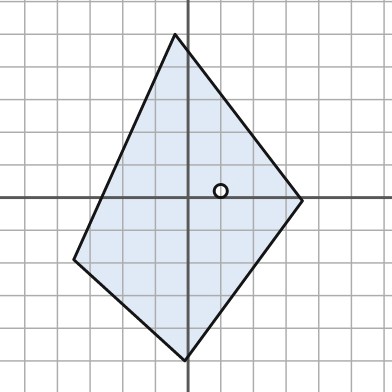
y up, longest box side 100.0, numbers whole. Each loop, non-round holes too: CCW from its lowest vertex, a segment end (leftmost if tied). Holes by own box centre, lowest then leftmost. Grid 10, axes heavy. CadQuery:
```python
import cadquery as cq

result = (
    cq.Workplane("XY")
    .moveTo(-1.0, -50.0)
    .lineTo(35.0, -1.0)
    .lineTo(-4.0, 50.0)
    .lineTo(-35.0, -19.0)
    .close()
    .moveTo(10.0, 2.0)
    .circle(2.0)
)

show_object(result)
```